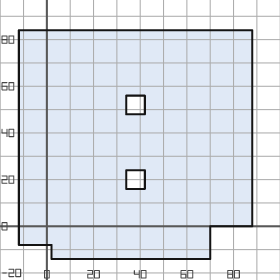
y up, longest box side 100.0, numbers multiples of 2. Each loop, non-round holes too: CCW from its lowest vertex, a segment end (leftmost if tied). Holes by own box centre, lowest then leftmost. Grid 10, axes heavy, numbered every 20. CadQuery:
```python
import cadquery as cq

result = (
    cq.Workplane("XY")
    .moveTo(2.0, -14.0)
    .lineTo(70.0, -14.0)
    .lineTo(70.0, 0.0)
    .lineTo(88.0, 0.0)
    .lineTo(88.0, 84.0)
    .lineTo(-12.0, 84.0)
    .lineTo(-12.0, -8.0)
    .lineTo(2.0, -8.0)
    .close()
    .moveTo(34.0, 16.0)
    .lineTo(42.0, 16.0)
    .lineTo(42.0, 24.0)
    .lineTo(34.0, 24.0)
    .close()
    .moveTo(34.0, 48.0)
    .lineTo(42.0, 48.0)
    .lineTo(42.0, 56.0)
    .lineTo(34.0, 56.0)
    .close()
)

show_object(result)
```